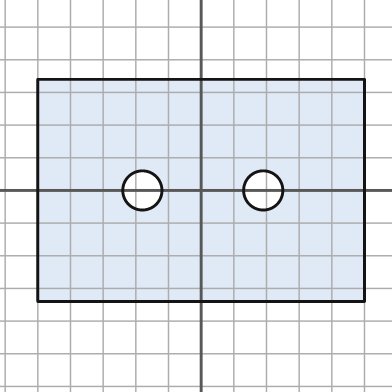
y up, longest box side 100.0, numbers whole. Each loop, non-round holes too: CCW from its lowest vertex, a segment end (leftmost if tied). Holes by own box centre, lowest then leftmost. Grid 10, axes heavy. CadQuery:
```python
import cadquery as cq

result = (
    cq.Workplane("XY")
    .moveTo(-50.0, -34.0)
    .lineTo(50.0, -34.0)
    .lineTo(50.0, 34.0)
    .lineTo(-50.0, 34.0)
    .close()
    .moveTo(-18.0, 0.0)
    .circle(6.0)
    .moveTo(19.0, 0.0)
    .circle(6.0)
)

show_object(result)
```